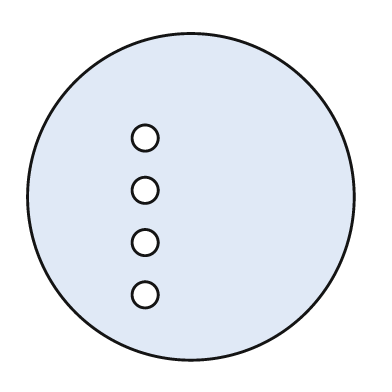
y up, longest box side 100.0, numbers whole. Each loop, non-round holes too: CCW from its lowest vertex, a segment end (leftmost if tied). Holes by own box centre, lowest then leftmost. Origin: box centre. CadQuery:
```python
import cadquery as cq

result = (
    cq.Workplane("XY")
    .moveTo(0.0, 0.0)
    .circle(50.0)
    .moveTo(-14.0, -30.0)
    .circle(4.0)
    .moveTo(-14.0, -14.0)
    .circle(4.0)
    .moveTo(-14.0, 2.0)
    .circle(4.0)
    .moveTo(-14.0, 18.0)
    .circle(4.0)
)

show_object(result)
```